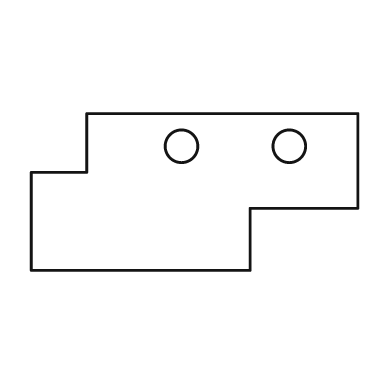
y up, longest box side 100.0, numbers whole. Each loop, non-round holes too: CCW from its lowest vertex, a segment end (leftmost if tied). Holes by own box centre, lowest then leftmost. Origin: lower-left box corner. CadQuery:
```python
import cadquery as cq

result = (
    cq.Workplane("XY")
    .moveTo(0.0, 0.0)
    .lineTo(67.0, 0.0)
    .lineTo(67.0, 19.0)
    .lineTo(100.0, 19.0)
    .lineTo(100.0, 48.0)
    .lineTo(17.0, 48.0)
    .lineTo(17.0, 30.0)
    .lineTo(0.0, 30.0)
    .close()
    .moveTo(46.0, 38.0)
    .circle(5.0)
    .moveTo(79.0, 38.0)
    .circle(5.0)
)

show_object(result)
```